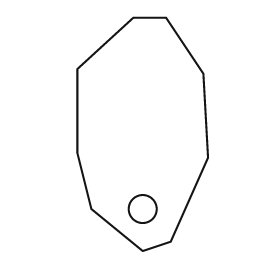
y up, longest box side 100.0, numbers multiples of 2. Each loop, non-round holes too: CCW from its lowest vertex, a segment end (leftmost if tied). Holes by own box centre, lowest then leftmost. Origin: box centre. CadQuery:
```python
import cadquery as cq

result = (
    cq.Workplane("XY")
    .moveTo(0.0, -50.0)
    .lineTo(12.0, -46.0)
    .lineTo(28.0, -10.0)
    .lineTo(26.0, 26.0)
    .lineTo(10.0, 50.0)
    .lineTo(-4.0, 50.0)
    .lineTo(-28.0, 28.0)
    .lineTo(-28.0, -8.0)
    .lineTo(-22.0, -32.0)
    .close()
    .moveTo(0.0, -32.0)
    .circle(6.0)
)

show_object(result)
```